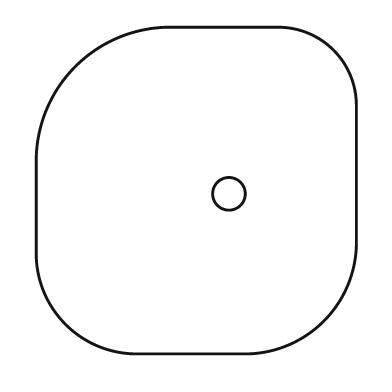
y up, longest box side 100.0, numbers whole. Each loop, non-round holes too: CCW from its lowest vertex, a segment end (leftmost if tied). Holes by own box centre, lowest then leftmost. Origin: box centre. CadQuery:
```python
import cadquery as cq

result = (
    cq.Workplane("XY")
    .moveTo(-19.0, -50.0)
    .lineTo(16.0, -50.0)
    .threePointArc((39.0, -40.0), (49.0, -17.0))
    .lineTo(49.0, 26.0)
    .threePointArc((42.0, 43.0), (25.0, 50.0))
    .lineTo(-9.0, 50.0)
    .threePointArc((-37.0, 38.0), (-49.0, 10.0))
    .lineTo(-49.0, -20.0)
    .threePointArc((-40.0, -41.0), (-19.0, -50.0))
    .close()
    .moveTo(10.0, -1.0)
    .circle(5.0)
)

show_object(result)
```